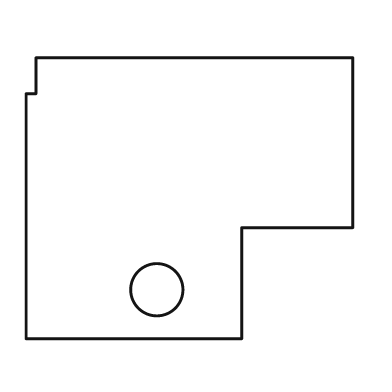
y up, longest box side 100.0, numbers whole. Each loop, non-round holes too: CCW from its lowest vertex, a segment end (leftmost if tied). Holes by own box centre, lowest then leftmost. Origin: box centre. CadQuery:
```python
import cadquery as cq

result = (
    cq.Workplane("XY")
    .moveTo(-50.0, -43.0)
    .lineTo(16.0, -43.0)
    .lineTo(16.0, -9.0)
    .lineTo(50.0, -9.0)
    .lineTo(50.0, 43.0)
    .lineTo(-47.0, 43.0)
    .lineTo(-47.0, 32.0)
    .lineTo(-50.0, 32.0)
    .close()
    .moveTo(-10.0, -28.0)
    .circle(8.0)
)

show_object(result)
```